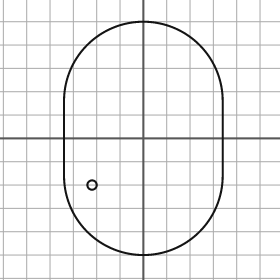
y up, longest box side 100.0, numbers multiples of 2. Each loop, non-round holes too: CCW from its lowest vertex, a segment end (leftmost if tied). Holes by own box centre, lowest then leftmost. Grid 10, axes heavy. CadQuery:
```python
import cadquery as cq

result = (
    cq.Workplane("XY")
    .moveTo(-34.0, -16.0)
    .threePointArc((0.0, -50.0), (34.0, -16.0))
    .lineTo(34.0, 16.0)
    .threePointArc((0.0, 50.0), (-34.0, 16.0))
    .close()
    .moveTo(-22.0, -20.0)
    .circle(2.0)
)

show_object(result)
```